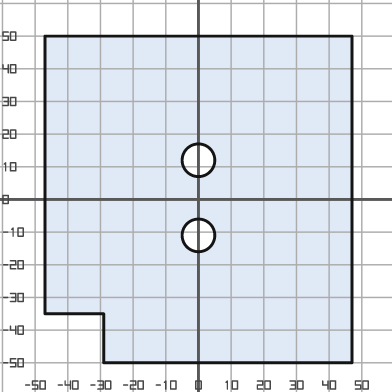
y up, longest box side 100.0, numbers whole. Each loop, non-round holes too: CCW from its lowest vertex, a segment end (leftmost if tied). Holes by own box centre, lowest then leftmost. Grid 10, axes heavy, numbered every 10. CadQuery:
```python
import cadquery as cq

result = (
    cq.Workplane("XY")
    .moveTo(-29.0, -50.0)
    .lineTo(47.0, -50.0)
    .lineTo(47.0, 50.0)
    .lineTo(-47.0, 50.0)
    .lineTo(-47.0, -35.0)
    .lineTo(-29.0, -35.0)
    .close()
    .moveTo(0.0, -11.0)
    .circle(5.0)
    .moveTo(0.0, 12.0)
    .circle(5.0)
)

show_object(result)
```